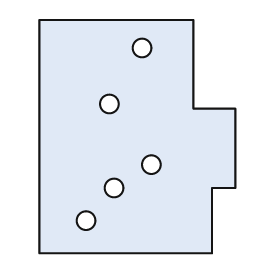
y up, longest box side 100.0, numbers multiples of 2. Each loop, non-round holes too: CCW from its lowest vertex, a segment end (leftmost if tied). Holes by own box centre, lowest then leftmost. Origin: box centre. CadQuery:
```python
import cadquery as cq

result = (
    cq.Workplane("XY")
    .moveTo(-42.0, -50.0)
    .lineTo(32.0, -50.0)
    .lineTo(32.0, -22.0)
    .lineTo(42.0, -22.0)
    .lineTo(42.0, 12.0)
    .lineTo(24.0, 12.0)
    .lineTo(24.0, 50.0)
    .lineTo(-42.0, 50.0)
    .close()
    .moveTo(-22.0, -36.0)
    .circle(4.0)
    .moveTo(-10.0, -22.0)
    .circle(4.0)
    .moveTo(6.0, -12.0)
    .circle(4.0)
    .moveTo(-12.0, 14.0)
    .circle(4.0)
    .moveTo(2.0, 38.0)
    .circle(4.0)
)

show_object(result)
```